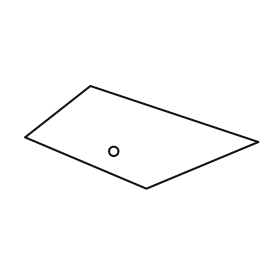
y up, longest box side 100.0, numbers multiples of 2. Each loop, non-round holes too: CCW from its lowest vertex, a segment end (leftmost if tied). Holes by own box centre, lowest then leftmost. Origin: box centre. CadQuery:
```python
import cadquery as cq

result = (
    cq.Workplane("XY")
    .moveTo(2.0, -22.0)
    .lineTo(50.0, -2.0)
    .lineTo(-22.0, 22.0)
    .lineTo(-50.0, 0.0)
    .close()
    .moveTo(-12.0, -6.0)
    .circle(2.0)
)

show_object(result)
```